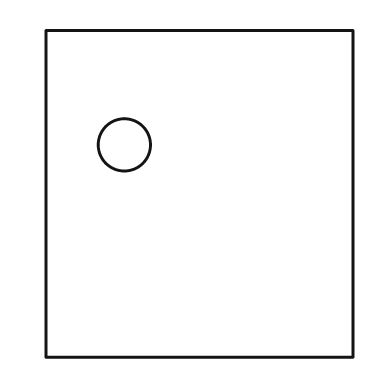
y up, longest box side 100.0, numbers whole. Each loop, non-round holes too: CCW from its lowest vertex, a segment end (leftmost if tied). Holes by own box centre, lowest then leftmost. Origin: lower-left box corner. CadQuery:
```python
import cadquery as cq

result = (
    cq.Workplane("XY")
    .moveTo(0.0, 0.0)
    .lineTo(94.0, 0.0)
    .lineTo(94.0, 100.0)
    .lineTo(0.0, 100.0)
    .close()
    .moveTo(24.0, 65.0)
    .circle(8.0)
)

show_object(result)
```